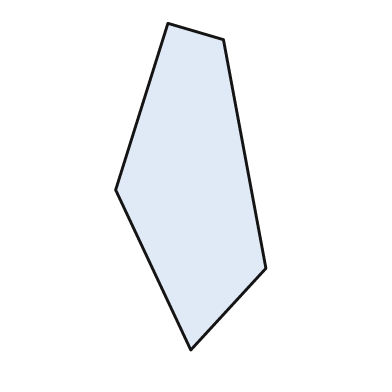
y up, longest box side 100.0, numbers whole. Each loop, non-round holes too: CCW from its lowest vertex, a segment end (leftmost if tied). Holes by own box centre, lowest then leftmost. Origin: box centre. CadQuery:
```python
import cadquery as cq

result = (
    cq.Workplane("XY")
    .moveTo(0.0, -50.0)
    .lineTo(23.0, -25.0)
    .lineTo(10.0, 45.0)
    .lineTo(-7.0, 50.0)
    .lineTo(-23.0, -1.0)
    .close()
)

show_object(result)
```